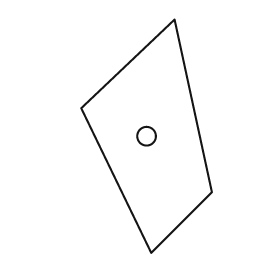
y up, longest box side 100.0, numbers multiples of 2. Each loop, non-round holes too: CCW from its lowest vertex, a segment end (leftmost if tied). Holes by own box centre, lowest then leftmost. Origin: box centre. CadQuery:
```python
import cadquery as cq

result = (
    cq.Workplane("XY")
    .moveTo(2.0, -50.0)
    .lineTo(28.0, -24.0)
    .lineTo(12.0, 50.0)
    .lineTo(-28.0, 12.0)
    .close()
    .moveTo(0.0, 0.0)
    .circle(4.0)
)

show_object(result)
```